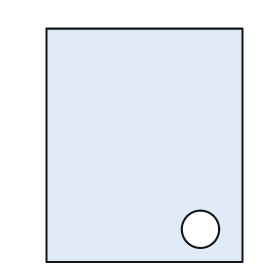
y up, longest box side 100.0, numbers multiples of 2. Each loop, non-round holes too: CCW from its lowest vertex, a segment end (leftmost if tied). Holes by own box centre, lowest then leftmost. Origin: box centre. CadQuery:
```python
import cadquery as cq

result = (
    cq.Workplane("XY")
    .moveTo(-42.0, -50.0)
    .lineTo(42.0, -50.0)
    .lineTo(42.0, 50.0)
    .lineTo(-42.0, 50.0)
    .close()
    .moveTo(24.0, -36.0)
    .circle(8.0)
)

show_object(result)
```